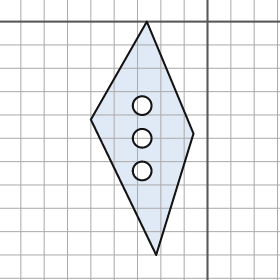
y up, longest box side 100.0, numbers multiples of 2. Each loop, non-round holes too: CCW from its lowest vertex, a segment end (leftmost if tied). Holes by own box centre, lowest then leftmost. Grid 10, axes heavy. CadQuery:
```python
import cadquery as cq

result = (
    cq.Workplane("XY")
    .moveTo(-22.0, -100.0)
    .lineTo(-6.0, -48.0)
    .lineTo(-26.0, 0.0)
    .lineTo(-50.0, -42.0)
    .close()
    .moveTo(-28.0, -64.0)
    .circle(4.0)
    .moveTo(-28.0, -50.0)
    .circle(4.0)
    .moveTo(-28.0, -36.0)
    .circle(4.0)
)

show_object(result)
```